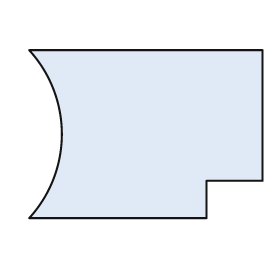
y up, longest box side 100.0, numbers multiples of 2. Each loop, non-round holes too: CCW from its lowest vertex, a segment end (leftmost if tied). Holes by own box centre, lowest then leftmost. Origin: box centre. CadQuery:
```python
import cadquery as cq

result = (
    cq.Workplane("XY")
    .moveTo(-50.0, -36.0)
    .lineTo(26.0, -36.0)
    .lineTo(26.0, -20.0)
    .lineTo(50.0, -20.0)
    .lineTo(50.0, 36.0)
    .lineTo(-50.0, 36.0)
    .threePointArc((-36.0, 0.0), (-50.0, -36.0))
    .close()
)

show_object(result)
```